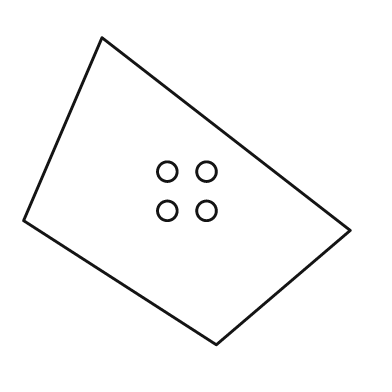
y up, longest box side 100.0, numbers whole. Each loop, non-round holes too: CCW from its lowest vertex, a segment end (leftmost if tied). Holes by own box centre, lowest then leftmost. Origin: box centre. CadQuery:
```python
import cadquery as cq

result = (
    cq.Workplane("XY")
    .moveTo(9.0, -47.0)
    .lineTo(50.0, -12.0)
    .lineTo(-26.0, 47.0)
    .lineTo(-50.0, -9.0)
    .close()
    .moveTo(-6.0, -6.0)
    .circle(3.0)
    .moveTo(6.0, -6.0)
    .circle(3.0)
    .moveTo(-6.0, 6.0)
    .circle(3.0)
    .moveTo(6.0, 6.0)
    .circle(3.0)
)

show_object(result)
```